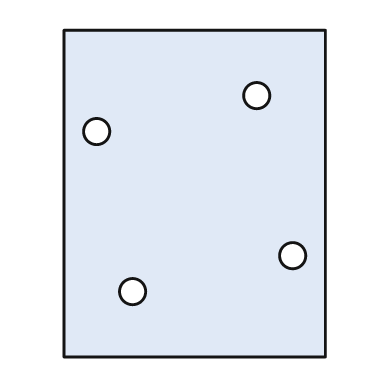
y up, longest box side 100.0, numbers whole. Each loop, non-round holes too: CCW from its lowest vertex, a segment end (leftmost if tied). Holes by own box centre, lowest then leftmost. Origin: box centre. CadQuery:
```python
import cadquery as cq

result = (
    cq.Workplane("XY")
    .moveTo(-40.0, -50.0)
    .lineTo(40.0, -50.0)
    .lineTo(40.0, 50.0)
    .lineTo(-40.0, 50.0)
    .close()
    .moveTo(-19.0, -30.0)
    .circle(4.0)
    .moveTo(30.0, -19.0)
    .circle(4.0)
    .moveTo(-30.0, 19.0)
    .circle(4.0)
    .moveTo(19.0, 30.0)
    .circle(4.0)
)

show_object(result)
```